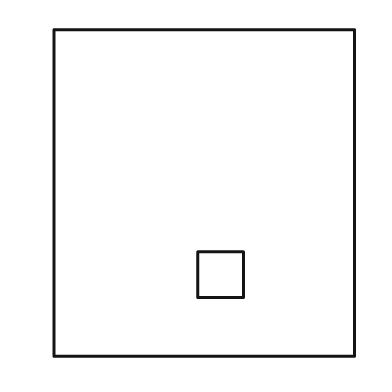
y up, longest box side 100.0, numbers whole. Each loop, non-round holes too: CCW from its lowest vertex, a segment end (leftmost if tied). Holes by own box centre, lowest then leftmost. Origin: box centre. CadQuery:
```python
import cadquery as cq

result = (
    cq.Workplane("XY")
    .moveTo(-46.0, -50.0)
    .lineTo(46.0, -50.0)
    .lineTo(46.0, 50.0)
    .lineTo(-46.0, 50.0)
    .close()
    .moveTo(-2.0, -32.0)
    .lineTo(12.0, -32.0)
    .lineTo(12.0, -18.0)
    .lineTo(-2.0, -18.0)
    .close()
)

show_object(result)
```